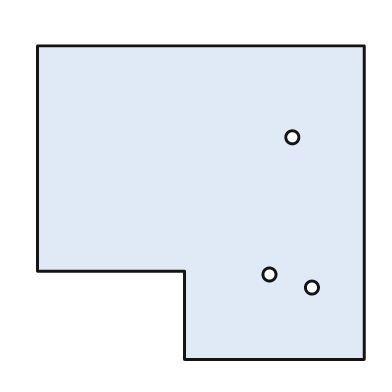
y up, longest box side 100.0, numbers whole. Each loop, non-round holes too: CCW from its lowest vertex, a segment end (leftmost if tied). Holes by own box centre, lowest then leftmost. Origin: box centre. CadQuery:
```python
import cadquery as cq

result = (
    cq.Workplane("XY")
    .moveTo(-5.0, -48.0)
    .lineTo(50.0, -48.0)
    .lineTo(50.0, 48.0)
    .lineTo(-50.0, 48.0)
    .lineTo(-50.0, -21.0)
    .lineTo(-5.0, -21.0)
    .close()
    .moveTo(34.0, -26.0)
    .circle(2.0)
    .moveTo(21.0, -22.0)
    .circle(2.0)
    .moveTo(28.0, 20.0)
    .circle(2.0)
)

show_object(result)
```